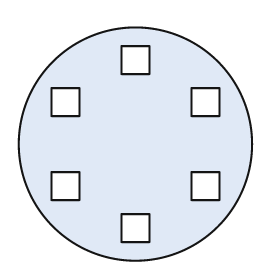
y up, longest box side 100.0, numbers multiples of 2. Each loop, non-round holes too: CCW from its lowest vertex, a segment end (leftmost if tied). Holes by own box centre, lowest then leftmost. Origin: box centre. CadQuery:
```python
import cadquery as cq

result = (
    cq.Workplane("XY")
    .moveTo(0.0, 0.0)
    .circle(50.0)
    .moveTo(-6.0, -42.0)
    .lineTo(6.0, -42.0)
    .lineTo(6.0, -30.0)
    .lineTo(-6.0, -30.0)
    .close()
    .moveTo(-36.0, -24.0)
    .lineTo(-24.0, -24.0)
    .lineTo(-24.0, -12.0)
    .lineTo(-36.0, -12.0)
    .close()
    .moveTo(24.0, -24.0)
    .lineTo(36.0, -24.0)
    .lineTo(36.0, -12.0)
    .lineTo(24.0, -12.0)
    .close()
    .moveTo(-36.0, 12.0)
    .lineTo(-24.0, 12.0)
    .lineTo(-24.0, 24.0)
    .lineTo(-36.0, 24.0)
    .close()
    .moveTo(24.0, 12.0)
    .lineTo(36.0, 12.0)
    .lineTo(36.0, 24.0)
    .lineTo(24.0, 24.0)
    .close()
    .moveTo(-6.0, 30.0)
    .lineTo(6.0, 30.0)
    .lineTo(6.0, 42.0)
    .lineTo(-6.0, 42.0)
    .close()
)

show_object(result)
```